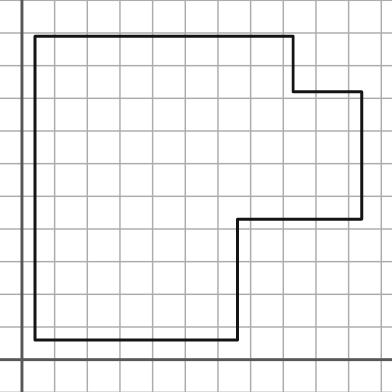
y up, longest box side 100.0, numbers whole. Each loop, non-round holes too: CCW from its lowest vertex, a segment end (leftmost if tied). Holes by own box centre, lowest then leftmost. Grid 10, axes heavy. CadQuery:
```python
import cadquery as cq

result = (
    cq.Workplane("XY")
    .moveTo(4.0, 6.0)
    .lineTo(66.0, 6.0)
    .lineTo(66.0, 43.0)
    .lineTo(104.0, 43.0)
    .lineTo(104.0, 82.0)
    .lineTo(83.0, 82.0)
    .lineTo(83.0, 99.0)
    .lineTo(4.0, 99.0)
    .close()
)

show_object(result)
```